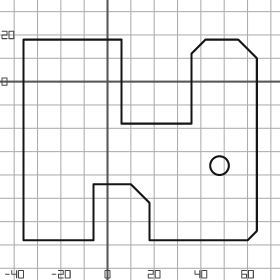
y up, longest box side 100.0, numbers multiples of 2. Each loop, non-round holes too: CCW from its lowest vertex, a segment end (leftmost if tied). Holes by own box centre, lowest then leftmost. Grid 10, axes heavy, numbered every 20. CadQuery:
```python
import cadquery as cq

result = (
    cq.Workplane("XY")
    .moveTo(-36.0, -68.0)
    .lineTo(-6.0, -68.0)
    .lineTo(-6.0, -44.0)
    .lineTo(10.0, -44.0)
    .lineTo(18.0, -52.0)
    .lineTo(18.0, -68.0)
    .lineTo(60.0, -68.0)
    .lineTo(64.0, -64.0)
    .lineTo(64.0, 10.0)
    .lineTo(56.0, 18.0)
    .lineTo(42.0, 18.0)
    .lineTo(36.0, 12.0)
    .lineTo(36.0, -18.0)
    .lineTo(6.0, -18.0)
    .lineTo(6.0, 18.0)
    .lineTo(-36.0, 18.0)
    .close()
    .moveTo(48.0, -36.0)
    .circle(4.0)
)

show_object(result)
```